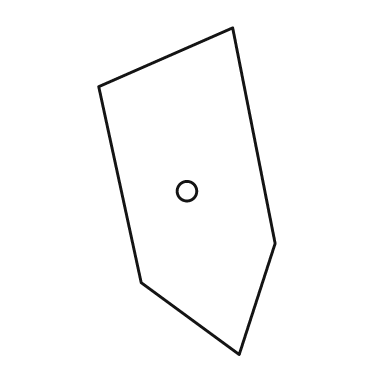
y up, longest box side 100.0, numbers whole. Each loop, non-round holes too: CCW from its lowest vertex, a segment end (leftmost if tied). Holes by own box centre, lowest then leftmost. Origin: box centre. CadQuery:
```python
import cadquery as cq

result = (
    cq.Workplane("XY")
    .moveTo(16.0, -50.0)
    .lineTo(27.0, -16.0)
    .lineTo(14.0, 50.0)
    .lineTo(-27.0, 32.0)
    .lineTo(-14.0, -28.0)
    .close()
    .moveTo(0.0, 0.0)
    .circle(3.0)
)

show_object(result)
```